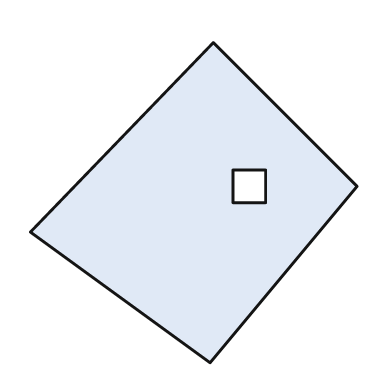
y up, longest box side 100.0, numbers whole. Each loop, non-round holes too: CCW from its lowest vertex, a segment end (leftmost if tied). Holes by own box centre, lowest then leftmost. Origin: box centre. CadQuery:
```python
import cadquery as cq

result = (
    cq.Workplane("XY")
    .moveTo(5.0, -49.0)
    .lineTo(50.0, 5.0)
    .lineTo(6.0, 49.0)
    .lineTo(-50.0, -9.0)
    .close()
    .moveTo(12.0, 0.0)
    .lineTo(22.0, 0.0)
    .lineTo(22.0, 10.0)
    .lineTo(12.0, 10.0)
    .close()
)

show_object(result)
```